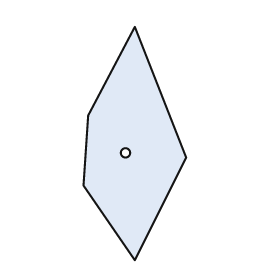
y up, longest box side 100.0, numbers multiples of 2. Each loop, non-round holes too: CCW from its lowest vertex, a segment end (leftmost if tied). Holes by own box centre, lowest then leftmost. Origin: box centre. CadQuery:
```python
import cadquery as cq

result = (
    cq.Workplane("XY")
    .moveTo(0.0, -50.0)
    .lineTo(22.0, -6.0)
    .lineTo(0.0, 50.0)
    .lineTo(-20.0, 12.0)
    .lineTo(-22.0, -18.0)
    .close()
    .moveTo(-4.0, -4.0)
    .circle(2.0)
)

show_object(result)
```